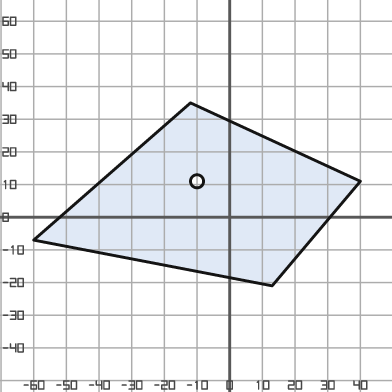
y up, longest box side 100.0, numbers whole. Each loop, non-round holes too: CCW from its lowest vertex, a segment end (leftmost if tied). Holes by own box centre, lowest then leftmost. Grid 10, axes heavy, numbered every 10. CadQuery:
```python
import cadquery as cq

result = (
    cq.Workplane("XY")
    .moveTo(13.0, -21.0)
    .lineTo(40.0, 11.0)
    .lineTo(-12.0, 35.0)
    .lineTo(-60.0, -7.0)
    .close()
    .moveTo(-10.0, 11.0)
    .circle(2.0)
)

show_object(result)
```